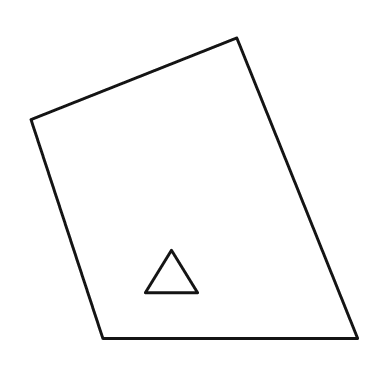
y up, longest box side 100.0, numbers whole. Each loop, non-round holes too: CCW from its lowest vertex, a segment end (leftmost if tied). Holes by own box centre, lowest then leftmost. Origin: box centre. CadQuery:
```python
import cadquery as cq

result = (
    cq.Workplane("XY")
    .moveTo(-28.0, -46.0)
    .lineTo(50.0, -46.0)
    .lineTo(13.0, 46.0)
    .lineTo(-50.0, 21.0)
    .close()
    .moveTo(-15.0, -32.0)
    .lineTo(1.0, -32.0)
    .lineTo(-7.0, -19.0)
    .close()
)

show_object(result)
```